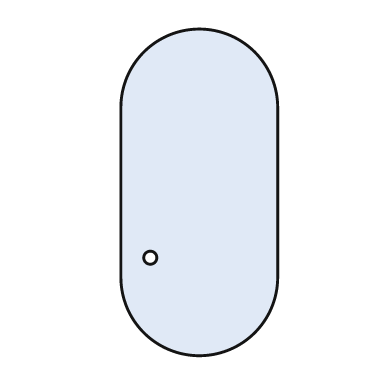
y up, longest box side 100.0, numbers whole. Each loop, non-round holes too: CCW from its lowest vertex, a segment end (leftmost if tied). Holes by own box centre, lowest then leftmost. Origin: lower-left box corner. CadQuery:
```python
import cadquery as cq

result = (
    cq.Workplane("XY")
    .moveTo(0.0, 24.0)
    .threePointArc((24.0, 0.0), (48.0, 24.0))
    .lineTo(48.0, 76.0)
    .threePointArc((24.0, 100.0), (0.0, 76.0))
    .close()
    .moveTo(9.0, 30.0)
    .circle(2.0)
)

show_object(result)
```